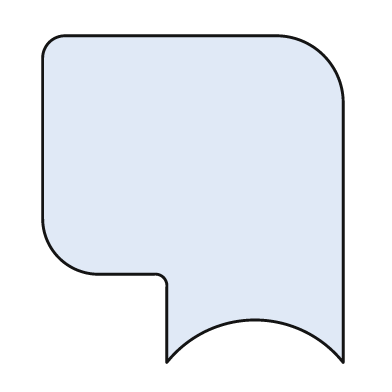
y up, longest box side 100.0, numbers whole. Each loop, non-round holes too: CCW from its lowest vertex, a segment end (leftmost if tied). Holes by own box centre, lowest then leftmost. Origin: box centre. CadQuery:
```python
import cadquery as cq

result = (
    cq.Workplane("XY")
    .moveTo(-8.0, -50.0)
    .threePointArc((19.0, -37.0), (46.0, -50.0))
    .lineTo(46.0, 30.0)
    .threePointArc((40.0, 44.0), (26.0, 50.0))
    .lineTo(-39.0, 50.0)
    .threePointArc((-44.0, 48.0), (-46.0, 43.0))
    .lineTo(-46.0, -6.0)
    .threePointArc((-41.0, -18.0), (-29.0, -23.0))
    .lineTo(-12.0, -23.0)
    .threePointArc((-9.0, -24.0), (-8.0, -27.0))
    .close()
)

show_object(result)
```